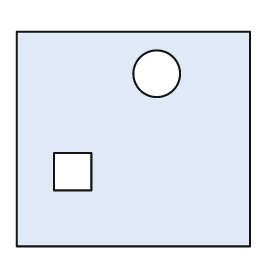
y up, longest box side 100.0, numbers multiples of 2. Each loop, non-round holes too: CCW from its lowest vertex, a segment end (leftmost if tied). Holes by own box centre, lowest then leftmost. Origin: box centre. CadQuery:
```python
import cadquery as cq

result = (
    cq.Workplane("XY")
    .moveTo(-50.0, -46.0)
    .lineTo(50.0, -46.0)
    .lineTo(50.0, 46.0)
    .lineTo(-50.0, 46.0)
    .close()
    .moveTo(-34.0, -22.0)
    .lineTo(-18.0, -22.0)
    .lineTo(-18.0, -6.0)
    .lineTo(-34.0, -6.0)
    .close()
    .moveTo(10.0, 28.0)
    .circle(10.0)
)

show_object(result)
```